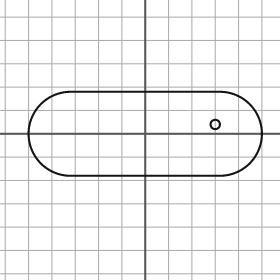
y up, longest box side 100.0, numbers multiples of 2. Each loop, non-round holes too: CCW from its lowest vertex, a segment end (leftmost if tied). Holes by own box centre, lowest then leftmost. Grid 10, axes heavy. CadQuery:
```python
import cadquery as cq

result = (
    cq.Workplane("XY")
    .moveTo(-32.0, -18.0)
    .lineTo(32.0, -18.0)
    .threePointArc((50.0, 0.0), (32.0, 18.0))
    .lineTo(-32.0, 18.0)
    .threePointArc((-50.0, 0.0), (-32.0, -18.0))
    .close()
    .moveTo(30.0, 4.0)
    .circle(2.0)
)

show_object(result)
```